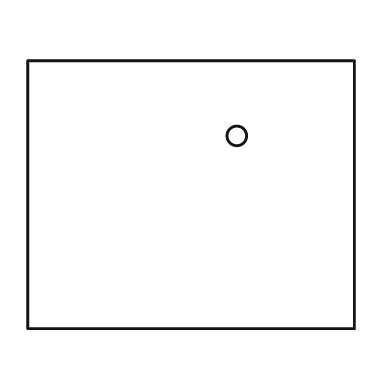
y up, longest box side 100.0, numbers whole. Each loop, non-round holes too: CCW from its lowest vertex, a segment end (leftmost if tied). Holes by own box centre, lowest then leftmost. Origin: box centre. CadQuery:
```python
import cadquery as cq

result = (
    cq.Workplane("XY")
    .moveTo(-50.0, -41.0)
    .lineTo(50.0, -41.0)
    .lineTo(50.0, 41.0)
    .lineTo(-50.0, 41.0)
    .close()
    .moveTo(14.0, 18.0)
    .circle(3.0)
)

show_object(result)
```